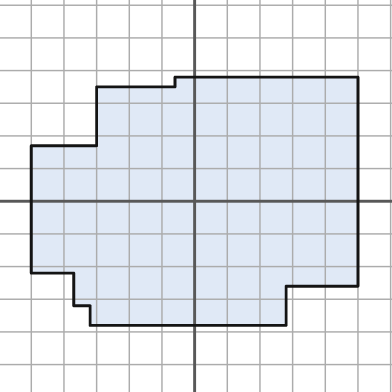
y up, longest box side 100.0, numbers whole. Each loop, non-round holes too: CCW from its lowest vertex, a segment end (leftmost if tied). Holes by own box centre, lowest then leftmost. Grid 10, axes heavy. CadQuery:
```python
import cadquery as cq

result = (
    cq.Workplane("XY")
    .moveTo(-32.0, -38.0)
    .lineTo(28.0, -38.0)
    .lineTo(28.0, -26.0)
    .lineTo(50.0, -26.0)
    .lineTo(50.0, 38.0)
    .lineTo(-6.0, 38.0)
    .lineTo(-6.0, 35.0)
    .lineTo(-30.0, 35.0)
    .lineTo(-30.0, 17.0)
    .lineTo(-50.0, 17.0)
    .lineTo(-50.0, -22.0)
    .lineTo(-37.0, -22.0)
    .lineTo(-37.0, -32.0)
    .lineTo(-32.0, -32.0)
    .close()
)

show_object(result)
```